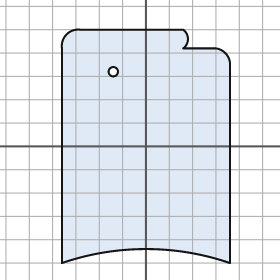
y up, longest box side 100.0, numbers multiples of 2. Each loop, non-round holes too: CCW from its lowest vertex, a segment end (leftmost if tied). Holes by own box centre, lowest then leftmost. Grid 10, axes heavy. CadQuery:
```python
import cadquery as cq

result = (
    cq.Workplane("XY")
    .moveTo(-36.0, -50.0)
    .threePointArc((0.0, -44.0), (36.0, -50.0))
    .lineTo(36.0, 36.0)
    .threePointArc((34.0, 40.0), (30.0, 42.0))
    .lineTo(16.0, 42.0)
    .threePointArc((18.0, 46.0), (16.0, 50.0))
    .lineTo(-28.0, 50.0)
    .threePointArc((-34.0, 48.0), (-36.0, 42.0))
    .close()
    .moveTo(-14.0, 32.0)
    .circle(2.0)
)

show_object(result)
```